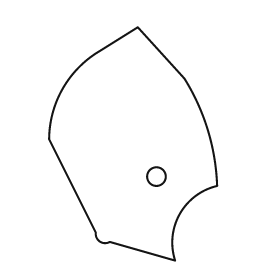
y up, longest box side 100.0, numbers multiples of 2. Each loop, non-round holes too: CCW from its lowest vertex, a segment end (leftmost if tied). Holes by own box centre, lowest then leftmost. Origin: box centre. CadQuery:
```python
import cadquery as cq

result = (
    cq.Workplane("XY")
    .moveTo(18.0, -50.0)
    .threePointArc((20.0, -30.0), (36.0, -18.0))
    .threePointArc((32.0, 6.0), (22.0, 28.0))
    .lineTo(2.0, 50.0)
    .lineTo(-14.0, 40.0)
    .threePointArc((-30.0, 24.0), (-36.0, 2.0))
    .lineTo(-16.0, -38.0)
    .threePointArc((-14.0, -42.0), (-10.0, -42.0))
    .close()
    .moveTo(10.0, -14.0)
    .circle(4.0)
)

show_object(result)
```